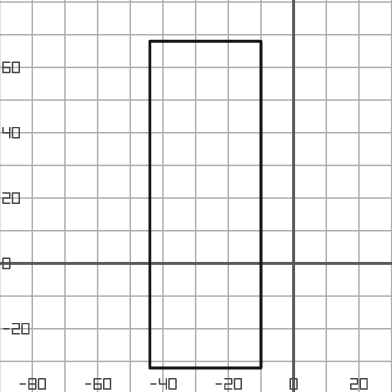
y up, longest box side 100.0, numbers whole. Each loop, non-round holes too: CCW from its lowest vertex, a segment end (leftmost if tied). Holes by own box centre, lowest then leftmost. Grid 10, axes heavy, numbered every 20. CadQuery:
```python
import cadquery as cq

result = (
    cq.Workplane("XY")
    .moveTo(-44.0, -32.0)
    .lineTo(-10.0, -32.0)
    .lineTo(-10.0, 68.0)
    .lineTo(-44.0, 68.0)
    .close()
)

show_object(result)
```